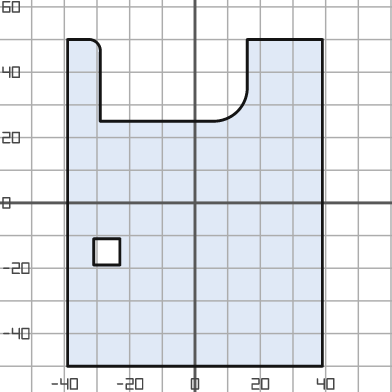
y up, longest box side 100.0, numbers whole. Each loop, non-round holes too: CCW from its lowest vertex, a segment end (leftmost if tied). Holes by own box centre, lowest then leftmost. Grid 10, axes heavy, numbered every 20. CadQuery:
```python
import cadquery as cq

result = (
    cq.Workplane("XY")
    .moveTo(-39.0, -50.0)
    .lineTo(39.0, -50.0)
    .lineTo(39.0, 50.0)
    .lineTo(16.0, 50.0)
    .lineTo(16.0, 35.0)
    .threePointArc((13.0, 28.0), (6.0, 25.0))
    .lineTo(-29.0, 25.0)
    .lineTo(-29.0, 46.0)
    .threePointArc((-30.0, 49.0), (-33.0, 50.0))
    .lineTo(-39.0, 50.0)
    .close()
    .moveTo(-31.0, -19.0)
    .lineTo(-23.0, -19.0)
    .lineTo(-23.0, -11.0)
    .lineTo(-31.0, -11.0)
    .close()
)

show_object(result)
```